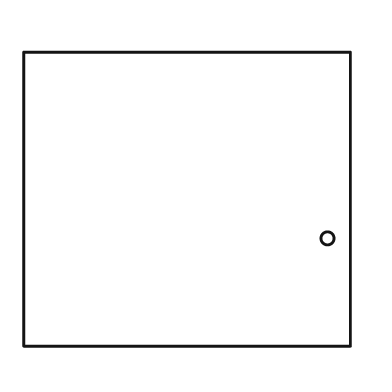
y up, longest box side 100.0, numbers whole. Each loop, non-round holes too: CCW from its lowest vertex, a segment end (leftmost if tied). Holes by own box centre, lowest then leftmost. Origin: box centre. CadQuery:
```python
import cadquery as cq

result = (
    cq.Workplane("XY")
    .moveTo(-50.0, -45.0)
    .lineTo(50.0, -45.0)
    .lineTo(50.0, 45.0)
    .lineTo(-50.0, 45.0)
    .close()
    .moveTo(43.0, -12.0)
    .circle(2.0)
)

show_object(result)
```